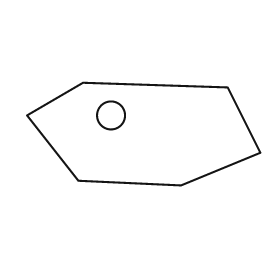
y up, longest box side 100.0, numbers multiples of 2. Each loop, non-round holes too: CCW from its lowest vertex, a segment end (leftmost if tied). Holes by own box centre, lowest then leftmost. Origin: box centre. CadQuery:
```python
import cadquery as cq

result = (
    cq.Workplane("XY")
    .moveTo(16.0, -22.0)
    .lineTo(50.0, -8.0)
    .lineTo(36.0, 20.0)
    .lineTo(-26.0, 22.0)
    .lineTo(-50.0, 8.0)
    .lineTo(-28.0, -20.0)
    .close()
    .moveTo(-14.0, 8.0)
    .circle(6.0)
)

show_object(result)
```